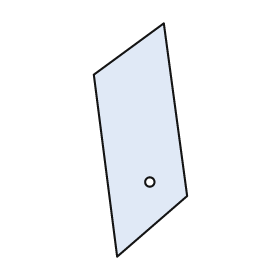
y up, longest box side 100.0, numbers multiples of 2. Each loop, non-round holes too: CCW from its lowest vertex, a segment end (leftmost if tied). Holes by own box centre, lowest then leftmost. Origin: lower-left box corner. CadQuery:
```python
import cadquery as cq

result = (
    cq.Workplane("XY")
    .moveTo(10.0, 0.0)
    .lineTo(40.0, 26.0)
    .lineTo(30.0, 100.0)
    .lineTo(0.0, 78.0)
    .close()
    .moveTo(24.0, 32.0)
    .circle(2.0)
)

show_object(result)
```